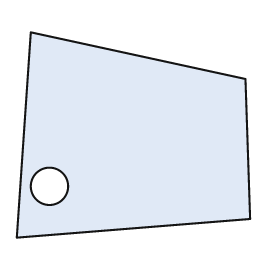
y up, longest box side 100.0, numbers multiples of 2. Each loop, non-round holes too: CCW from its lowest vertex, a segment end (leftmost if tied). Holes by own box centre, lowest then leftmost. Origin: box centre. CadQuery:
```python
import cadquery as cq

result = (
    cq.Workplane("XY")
    .moveTo(-50.0, -44.0)
    .lineTo(50.0, -36.0)
    .lineTo(48.0, 24.0)
    .lineTo(-44.0, 44.0)
    .close()
    .moveTo(-36.0, -22.0)
    .circle(8.0)
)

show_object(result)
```